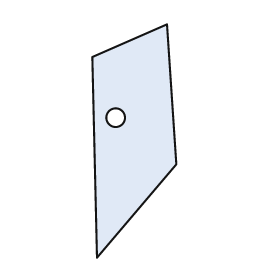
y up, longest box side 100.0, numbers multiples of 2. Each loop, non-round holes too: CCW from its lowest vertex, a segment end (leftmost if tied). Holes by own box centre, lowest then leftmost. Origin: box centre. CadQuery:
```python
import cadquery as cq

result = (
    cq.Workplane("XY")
    .moveTo(-16.0, -50.0)
    .lineTo(18.0, -10.0)
    .lineTo(14.0, 50.0)
    .lineTo(-18.0, 36.0)
    .close()
    .moveTo(-8.0, 10.0)
    .circle(4.0)
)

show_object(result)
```